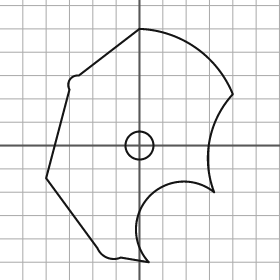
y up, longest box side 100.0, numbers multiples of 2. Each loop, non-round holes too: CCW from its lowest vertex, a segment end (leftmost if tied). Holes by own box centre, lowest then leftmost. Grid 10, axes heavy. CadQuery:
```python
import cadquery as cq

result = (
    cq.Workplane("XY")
    .moveTo(4.0, -50.0)
    .threePointArc((4.0, -22.0), (32.0, -20.0))
    .threePointArc((30.0, 2.0), (40.0, 22.0))
    .threePointArc((24.0, 42.0), (0.0, 50.0))
    .lineTo(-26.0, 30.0)
    .threePointArc((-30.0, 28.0), (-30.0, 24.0))
    .lineTo(-40.0, -14.0)
    .lineTo(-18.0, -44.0)
    .threePointArc((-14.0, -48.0), (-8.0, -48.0))
    .close()
    .moveTo(0.0, 0.0)
    .circle(6.0)
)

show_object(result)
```